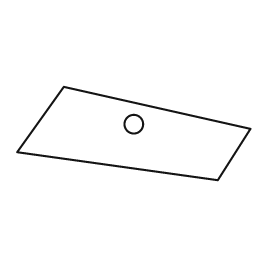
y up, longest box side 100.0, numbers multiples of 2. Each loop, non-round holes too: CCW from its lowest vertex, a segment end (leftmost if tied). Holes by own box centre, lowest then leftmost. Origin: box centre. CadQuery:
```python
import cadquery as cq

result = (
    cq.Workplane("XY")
    .moveTo(36.0, -20.0)
    .lineTo(50.0, 2.0)
    .lineTo(-30.0, 20.0)
    .lineTo(-50.0, -8.0)
    .close()
    .moveTo(0.0, 4.0)
    .circle(4.0)
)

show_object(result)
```